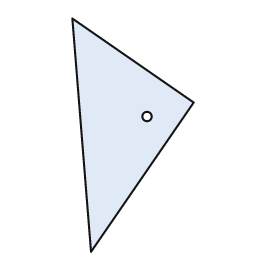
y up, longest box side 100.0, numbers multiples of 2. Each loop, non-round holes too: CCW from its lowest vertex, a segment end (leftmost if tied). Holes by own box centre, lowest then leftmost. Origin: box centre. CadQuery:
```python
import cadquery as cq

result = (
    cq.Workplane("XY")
    .moveTo(-18.0, -50.0)
    .lineTo(26.0, 14.0)
    .lineTo(-26.0, 50.0)
    .close()
    .moveTo(6.0, 8.0)
    .circle(2.0)
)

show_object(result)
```